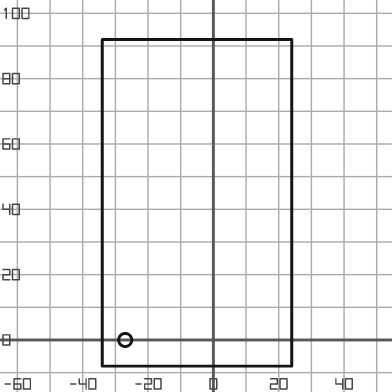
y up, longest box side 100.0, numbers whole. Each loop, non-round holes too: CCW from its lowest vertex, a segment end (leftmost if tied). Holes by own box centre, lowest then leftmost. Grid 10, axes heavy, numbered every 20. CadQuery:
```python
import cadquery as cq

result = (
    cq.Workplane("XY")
    .moveTo(-34.0, -8.0)
    .lineTo(24.0, -8.0)
    .lineTo(24.0, 92.0)
    .lineTo(-34.0, 92.0)
    .close()
    .moveTo(-27.0, 0.0)
    .circle(2.0)
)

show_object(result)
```